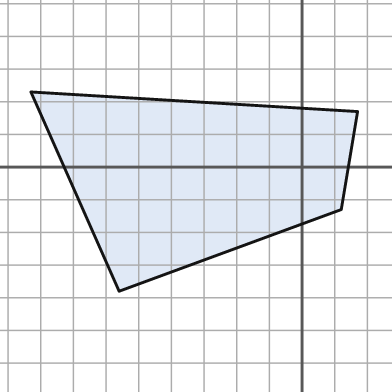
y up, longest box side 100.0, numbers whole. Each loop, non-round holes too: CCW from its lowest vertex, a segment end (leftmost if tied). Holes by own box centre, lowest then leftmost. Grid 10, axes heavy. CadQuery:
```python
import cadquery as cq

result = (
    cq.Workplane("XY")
    .moveTo(-56.0, -38.0)
    .lineTo(12.0, -13.0)
    .lineTo(17.0, 17.0)
    .lineTo(-83.0, 23.0)
    .close()
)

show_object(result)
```